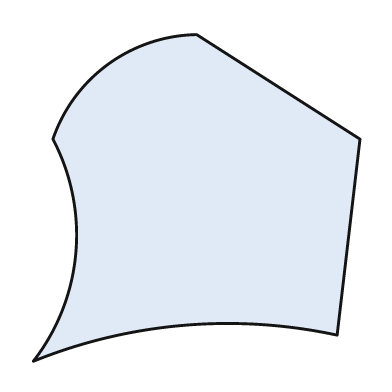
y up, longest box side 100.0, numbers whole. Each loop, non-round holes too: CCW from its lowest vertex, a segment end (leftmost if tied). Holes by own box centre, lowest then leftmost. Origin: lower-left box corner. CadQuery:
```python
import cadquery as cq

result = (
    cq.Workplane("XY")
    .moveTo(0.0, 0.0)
    .threePointArc((46.0, 11.0), (93.0, 8.0))
    .lineTo(100.0, 68.0)
    .lineTo(50.0, 100.0)
    .threePointArc((23.0, 91.0), (6.0, 68.0))
    .threePointArc((13.0, 33.0), (0.0, 0.0))
    .close()
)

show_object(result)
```